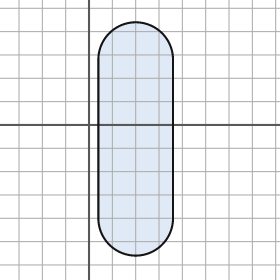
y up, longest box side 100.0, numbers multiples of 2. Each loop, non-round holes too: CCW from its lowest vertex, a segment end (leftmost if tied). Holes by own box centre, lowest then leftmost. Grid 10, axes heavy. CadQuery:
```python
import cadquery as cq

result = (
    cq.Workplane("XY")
    .moveTo(4.0, -40.0)
    .threePointArc((20.0, -56.0), (36.0, -40.0))
    .lineTo(36.0, 28.0)
    .threePointArc((20.0, 44.0), (4.0, 28.0))
    .close()
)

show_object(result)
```